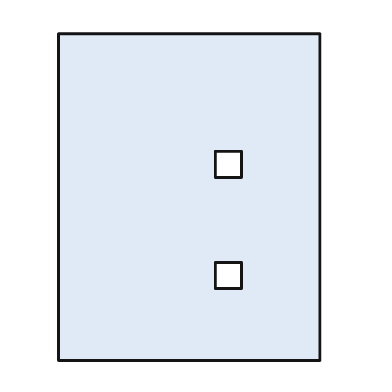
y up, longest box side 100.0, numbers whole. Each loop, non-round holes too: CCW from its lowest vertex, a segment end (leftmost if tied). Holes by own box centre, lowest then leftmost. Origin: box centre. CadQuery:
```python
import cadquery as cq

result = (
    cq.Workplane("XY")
    .moveTo(-40.0, -50.0)
    .lineTo(40.0, -50.0)
    .lineTo(40.0, 50.0)
    .lineTo(-40.0, 50.0)
    .close()
    .moveTo(8.0, -28.0)
    .lineTo(16.0, -28.0)
    .lineTo(16.0, -20.0)
    .lineTo(8.0, -20.0)
    .close()
    .moveTo(8.0, 6.0)
    .lineTo(16.0, 6.0)
    .lineTo(16.0, 14.0)
    .lineTo(8.0, 14.0)
    .close()
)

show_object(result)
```